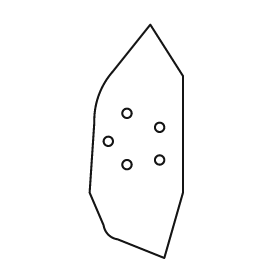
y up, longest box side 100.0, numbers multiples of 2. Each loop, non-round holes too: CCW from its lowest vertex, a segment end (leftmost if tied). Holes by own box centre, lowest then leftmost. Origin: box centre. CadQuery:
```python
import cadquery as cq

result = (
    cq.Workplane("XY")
    .moveTo(12.0, -50.0)
    .lineTo(20.0, -22.0)
    .lineTo(20.0, 28.0)
    .lineTo(6.0, 50.0)
    .lineTo(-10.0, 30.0)
    .threePointArc((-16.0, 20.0), (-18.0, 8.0))
    .lineTo(-20.0, -22.0)
    .lineTo(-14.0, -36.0)
    .threePointArc((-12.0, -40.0), (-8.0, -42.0))
    .close()
    .moveTo(-4.0, -10.0)
    .circle(2.0)
    .moveTo(10.0, -8.0)
    .circle(2.0)
    .moveTo(-12.0, 0.0)
    .circle(2.0)
    .moveTo(10.0, 6.0)
    .circle(2.0)
    .moveTo(-4.0, 12.0)
    .circle(2.0)
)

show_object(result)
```